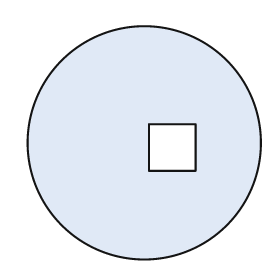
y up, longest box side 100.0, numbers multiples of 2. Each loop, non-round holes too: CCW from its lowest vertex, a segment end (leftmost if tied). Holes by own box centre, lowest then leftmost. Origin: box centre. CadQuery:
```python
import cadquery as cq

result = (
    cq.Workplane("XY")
    .moveTo(0.0, 0.0)
    .circle(50.0)
    .moveTo(2.0, -12.0)
    .lineTo(22.0, -12.0)
    .lineTo(22.0, 8.0)
    .lineTo(2.0, 8.0)
    .close()
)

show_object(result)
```